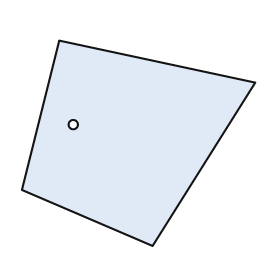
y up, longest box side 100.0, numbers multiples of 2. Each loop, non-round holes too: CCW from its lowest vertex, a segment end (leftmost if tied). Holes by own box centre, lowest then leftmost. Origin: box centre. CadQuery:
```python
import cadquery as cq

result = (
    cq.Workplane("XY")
    .moveTo(6.0, -44.0)
    .lineTo(50.0, 26.0)
    .lineTo(-34.0, 44.0)
    .lineTo(-50.0, -20.0)
    .close()
    .moveTo(-28.0, 8.0)
    .circle(2.0)
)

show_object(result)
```